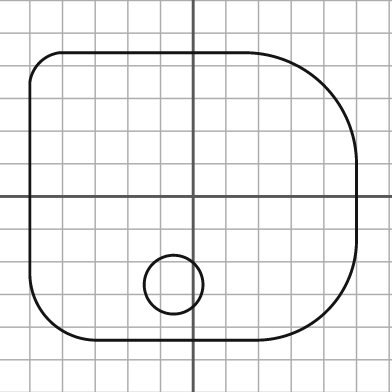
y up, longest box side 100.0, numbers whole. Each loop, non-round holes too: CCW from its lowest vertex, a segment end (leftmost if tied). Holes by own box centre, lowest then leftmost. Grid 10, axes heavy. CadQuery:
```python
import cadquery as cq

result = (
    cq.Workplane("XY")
    .moveTo(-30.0, -44.0)
    .lineTo(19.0, -44.0)
    .threePointArc((41.0, -35.0), (50.0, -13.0))
    .lineTo(50.0, 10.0)
    .threePointArc((40.0, 34.0), (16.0, 44.0))
    .lineTo(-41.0, 44.0)
    .threePointArc((-47.0, 41.0), (-50.0, 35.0))
    .lineTo(-50.0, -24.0)
    .threePointArc((-44.0, -38.0), (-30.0, -44.0))
    .close()
    .moveTo(-6.0, -27.0)
    .circle(9.0)
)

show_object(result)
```